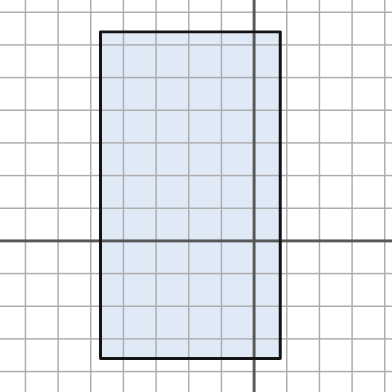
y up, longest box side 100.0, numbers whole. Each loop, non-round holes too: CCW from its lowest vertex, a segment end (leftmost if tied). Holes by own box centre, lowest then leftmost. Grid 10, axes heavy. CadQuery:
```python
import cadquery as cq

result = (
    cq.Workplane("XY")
    .moveTo(-47.0, -36.0)
    .lineTo(8.0, -36.0)
    .lineTo(8.0, 64.0)
    .lineTo(-47.0, 64.0)
    .close()
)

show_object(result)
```